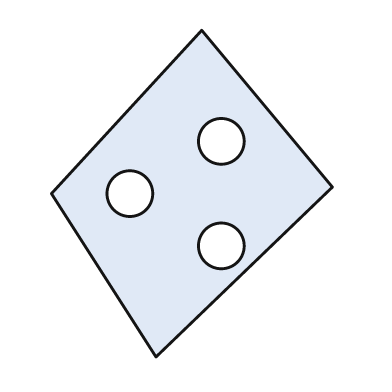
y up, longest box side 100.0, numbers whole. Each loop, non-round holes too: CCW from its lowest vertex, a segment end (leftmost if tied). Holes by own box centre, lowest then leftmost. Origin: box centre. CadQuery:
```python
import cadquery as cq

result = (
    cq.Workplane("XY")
    .moveTo(-11.0, -50.0)
    .lineTo(43.0, 2.0)
    .lineTo(3.0, 50.0)
    .lineTo(-43.0, 0.0)
    .close()
    .moveTo(9.0, -16.0)
    .circle(7.0)
    .moveTo(-19.0, 0.0)
    .circle(7.0)
    .moveTo(9.0, 16.0)
    .circle(7.0)
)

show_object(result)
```